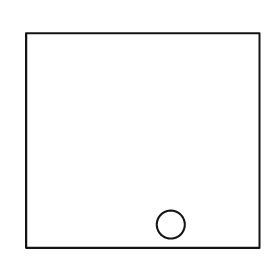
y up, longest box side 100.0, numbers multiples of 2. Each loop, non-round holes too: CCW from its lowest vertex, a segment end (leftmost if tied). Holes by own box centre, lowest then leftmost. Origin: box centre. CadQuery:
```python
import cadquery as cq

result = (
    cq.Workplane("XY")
    .moveTo(-50.0, -46.0)
    .lineTo(50.0, -46.0)
    .lineTo(50.0, 46.0)
    .lineTo(-50.0, 46.0)
    .close()
    .moveTo(12.0, -36.0)
    .circle(6.0)
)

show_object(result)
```